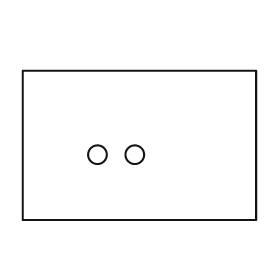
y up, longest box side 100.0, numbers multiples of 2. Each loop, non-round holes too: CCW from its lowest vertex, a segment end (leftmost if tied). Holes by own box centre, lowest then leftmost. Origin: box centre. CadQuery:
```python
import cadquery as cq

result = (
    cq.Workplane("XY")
    .moveTo(-50.0, -32.0)
    .lineTo(50.0, -32.0)
    .lineTo(50.0, 32.0)
    .lineTo(-50.0, 32.0)
    .close()
    .moveTo(-18.0, -4.0)
    .circle(4.0)
    .moveTo(-2.0, -4.0)
    .circle(4.0)
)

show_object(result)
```